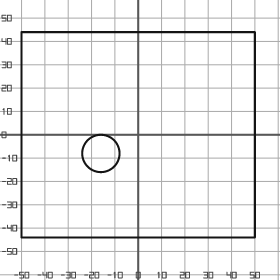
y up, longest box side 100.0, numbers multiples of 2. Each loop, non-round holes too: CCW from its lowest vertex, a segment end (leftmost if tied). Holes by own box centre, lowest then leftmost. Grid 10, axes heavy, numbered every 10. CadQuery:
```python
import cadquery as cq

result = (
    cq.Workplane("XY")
    .moveTo(-50.0, -44.0)
    .lineTo(50.0, -44.0)
    .lineTo(50.0, 44.0)
    .lineTo(-50.0, 44.0)
    .close()
    .moveTo(-16.0, -8.0)
    .circle(8.0)
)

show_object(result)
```